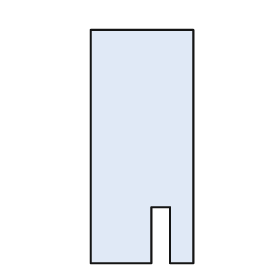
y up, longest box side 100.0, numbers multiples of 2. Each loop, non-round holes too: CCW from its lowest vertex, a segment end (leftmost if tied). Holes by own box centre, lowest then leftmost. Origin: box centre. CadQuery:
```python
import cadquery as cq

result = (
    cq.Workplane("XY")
    .moveTo(-22.0, -50.0)
    .lineTo(4.0, -50.0)
    .lineTo(4.0, -26.0)
    .lineTo(12.0, -26.0)
    .lineTo(12.0, -50.0)
    .lineTo(22.0, -50.0)
    .lineTo(22.0, 50.0)
    .lineTo(-22.0, 50.0)
    .close()
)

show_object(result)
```